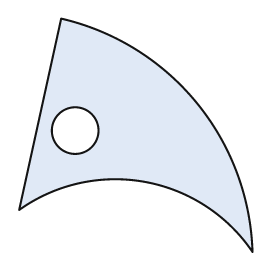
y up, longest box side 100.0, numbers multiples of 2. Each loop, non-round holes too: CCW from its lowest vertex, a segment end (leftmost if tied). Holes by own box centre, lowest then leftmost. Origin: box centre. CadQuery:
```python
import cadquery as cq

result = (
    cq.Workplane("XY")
    .moveTo(50.0, -50.0)
    .threePointArc((26.0, 14.0), (-32.0, 50.0))
    .lineTo(-50.0, -32.0)
    .threePointArc((4.0, -20.0), (50.0, -50.0))
    .close()
    .moveTo(-26.0, 2.0)
    .circle(10.0)
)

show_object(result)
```